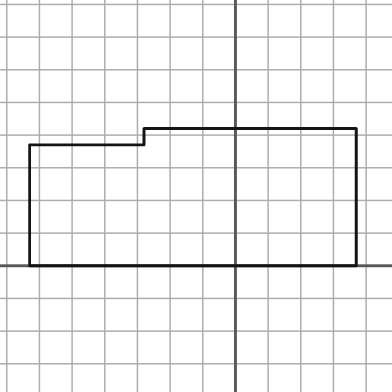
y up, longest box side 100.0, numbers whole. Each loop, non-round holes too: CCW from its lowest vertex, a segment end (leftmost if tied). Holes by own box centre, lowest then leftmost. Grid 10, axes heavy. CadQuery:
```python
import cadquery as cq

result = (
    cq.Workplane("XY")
    .moveTo(-63.0, 0.0)
    .lineTo(37.0, 0.0)
    .lineTo(37.0, 42.0)
    .lineTo(-28.0, 42.0)
    .lineTo(-28.0, 37.0)
    .lineTo(-63.0, 37.0)
    .close()
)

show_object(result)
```